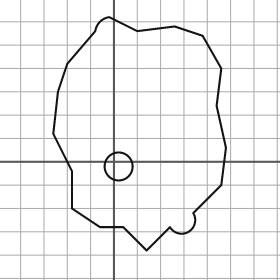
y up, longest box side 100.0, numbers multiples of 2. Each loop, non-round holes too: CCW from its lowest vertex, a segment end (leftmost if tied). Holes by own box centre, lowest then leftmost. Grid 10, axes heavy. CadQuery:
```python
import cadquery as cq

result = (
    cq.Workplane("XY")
    .moveTo(14.0, -38.0)
    .lineTo(24.0, -28.0)
    .threePointArc((32.0, -30.0), (34.0, -22.0))
    .lineTo(46.0, -10.0)
    .lineTo(48.0, 6.0)
    .lineTo(44.0, 24.0)
    .lineTo(46.0, 40.0)
    .lineTo(38.0, 54.0)
    .lineTo(26.0, 58.0)
    .lineTo(10.0, 56.0)
    .lineTo(-2.0, 62.0)
    .threePointArc((-6.0, 60.0), (-8.0, 56.0))
    .lineTo(-20.0, 42.0)
    .lineTo(-24.0, 30.0)
    .lineTo(-26.0, 12.0)
    .lineTo(-18.0, -4.0)
    .lineTo(-18.0, -20.0)
    .lineTo(-6.0, -28.0)
    .lineTo(4.0, -28.0)
    .close()
    .moveTo(2.0, -2.0)
    .circle(6.0)
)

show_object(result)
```